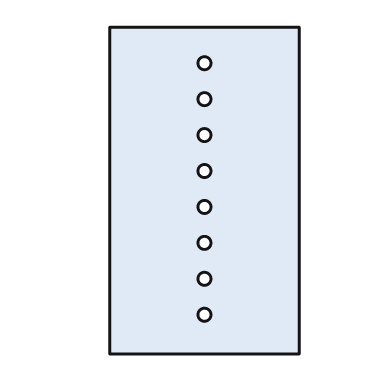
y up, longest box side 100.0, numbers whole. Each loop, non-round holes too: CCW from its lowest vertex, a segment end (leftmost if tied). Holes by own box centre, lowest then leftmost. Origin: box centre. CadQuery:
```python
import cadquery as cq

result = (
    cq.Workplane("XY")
    .moveTo(-29.0, -50.0)
    .lineTo(29.0, -50.0)
    .lineTo(29.0, 50.0)
    .lineTo(-29.0, 50.0)
    .close()
    .moveTo(0.0, -38.0)
    .circle(2.0)
    .moveTo(0.0, -27.0)
    .circle(2.0)
    .moveTo(0.0, -16.0)
    .circle(2.0)
    .moveTo(0.0, -5.0)
    .circle(2.0)
    .moveTo(0.0, 6.0)
    .circle(2.0)
    .moveTo(0.0, 17.0)
    .circle(2.0)
    .moveTo(0.0, 28.0)
    .circle(2.0)
    .moveTo(0.0, 39.0)
    .circle(2.0)
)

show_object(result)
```